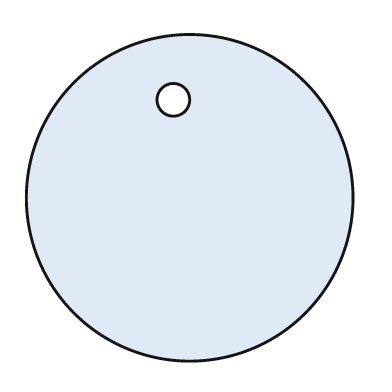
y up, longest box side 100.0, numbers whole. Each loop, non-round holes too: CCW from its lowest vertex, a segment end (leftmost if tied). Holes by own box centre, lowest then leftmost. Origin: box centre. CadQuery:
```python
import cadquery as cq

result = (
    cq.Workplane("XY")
    .moveTo(0.0, 0.0)
    .circle(50.0)
    .moveTo(-5.0, 30.0)
    .circle(5.0)
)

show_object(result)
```